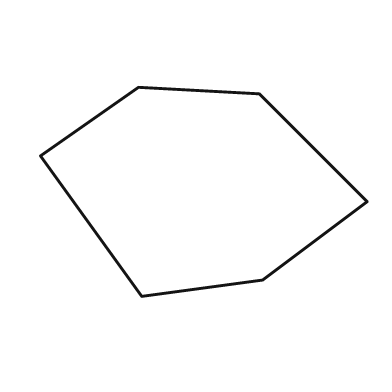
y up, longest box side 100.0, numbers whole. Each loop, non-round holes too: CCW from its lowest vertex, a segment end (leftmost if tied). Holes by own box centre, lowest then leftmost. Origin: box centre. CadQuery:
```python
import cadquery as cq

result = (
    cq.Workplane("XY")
    .moveTo(-19.0, -32.0)
    .lineTo(18.0, -27.0)
    .lineTo(50.0, -3.0)
    .lineTo(17.0, 30.0)
    .lineTo(-20.0, 32.0)
    .lineTo(-50.0, 11.0)
    .close()
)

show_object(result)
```